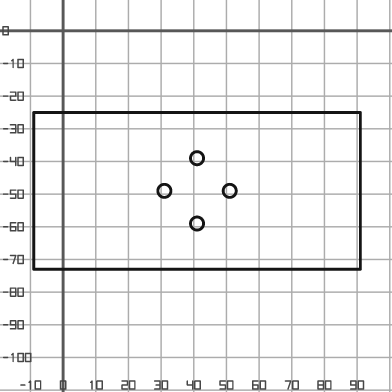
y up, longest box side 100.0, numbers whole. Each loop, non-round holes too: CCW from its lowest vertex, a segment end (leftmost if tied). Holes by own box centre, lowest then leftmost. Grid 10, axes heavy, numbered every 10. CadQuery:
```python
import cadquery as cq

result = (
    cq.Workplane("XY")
    .moveTo(-9.0, -73.0)
    .lineTo(91.0, -73.0)
    .lineTo(91.0, -25.0)
    .lineTo(-9.0, -25.0)
    .close()
    .moveTo(41.0, -59.0)
    .circle(2.0)
    .moveTo(31.0, -49.0)
    .circle(2.0)
    .moveTo(51.0, -49.0)
    .circle(2.0)
    .moveTo(41.0, -39.0)
    .circle(2.0)
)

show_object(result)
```